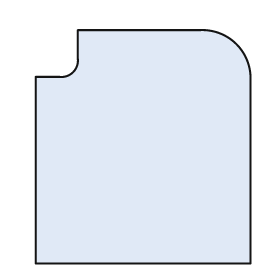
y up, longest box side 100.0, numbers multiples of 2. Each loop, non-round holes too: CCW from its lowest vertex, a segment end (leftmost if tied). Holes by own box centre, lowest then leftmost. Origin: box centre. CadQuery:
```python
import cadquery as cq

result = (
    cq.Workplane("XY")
    .moveTo(-46.0, -50.0)
    .lineTo(46.0, -50.0)
    .lineTo(46.0, 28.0)
    .threePointArc((40.0, 44.0), (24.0, 50.0))
    .lineTo(-28.0, 50.0)
    .lineTo(-28.0, 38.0)
    .threePointArc((-30.0, 32.0), (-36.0, 30.0))
    .lineTo(-46.0, 30.0)
    .close()
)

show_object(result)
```